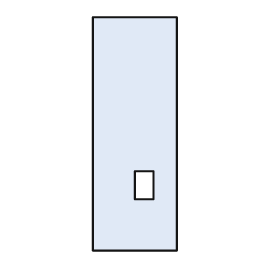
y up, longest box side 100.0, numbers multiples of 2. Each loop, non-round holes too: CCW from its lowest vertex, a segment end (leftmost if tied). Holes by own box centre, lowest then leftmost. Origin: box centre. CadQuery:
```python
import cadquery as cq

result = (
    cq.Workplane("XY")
    .moveTo(-18.0, -50.0)
    .lineTo(18.0, -50.0)
    .lineTo(18.0, 50.0)
    .lineTo(-18.0, 50.0)
    .close()
    .moveTo(0.0, -28.0)
    .lineTo(8.0, -28.0)
    .lineTo(8.0, -16.0)
    .lineTo(0.0, -16.0)
    .close()
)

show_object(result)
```